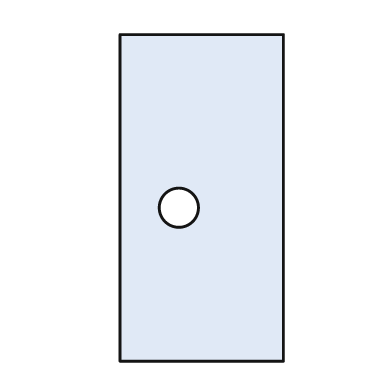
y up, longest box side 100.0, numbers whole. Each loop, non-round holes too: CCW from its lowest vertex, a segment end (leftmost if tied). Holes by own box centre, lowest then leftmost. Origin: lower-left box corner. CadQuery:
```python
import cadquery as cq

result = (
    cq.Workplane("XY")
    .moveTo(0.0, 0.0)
    .lineTo(50.0, 0.0)
    .lineTo(50.0, 100.0)
    .lineTo(0.0, 100.0)
    .close()
    .moveTo(18.0, 47.0)
    .circle(6.0)
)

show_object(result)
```